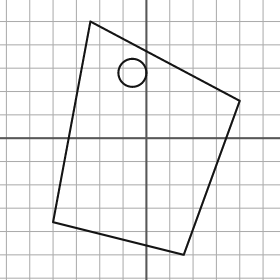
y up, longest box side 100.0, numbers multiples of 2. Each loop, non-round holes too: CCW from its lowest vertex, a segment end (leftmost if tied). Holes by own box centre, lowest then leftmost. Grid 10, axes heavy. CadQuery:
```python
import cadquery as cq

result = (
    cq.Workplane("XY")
    .moveTo(16.0, -50.0)
    .lineTo(40.0, 16.0)
    .lineTo(-24.0, 50.0)
    .lineTo(-40.0, -36.0)
    .close()
    .moveTo(-6.0, 28.0)
    .circle(6.0)
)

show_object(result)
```